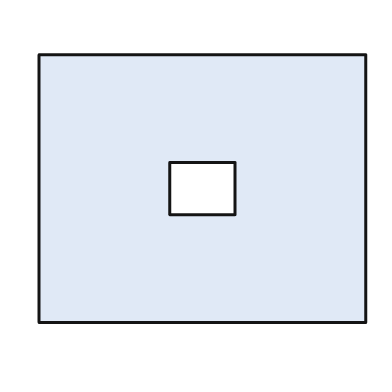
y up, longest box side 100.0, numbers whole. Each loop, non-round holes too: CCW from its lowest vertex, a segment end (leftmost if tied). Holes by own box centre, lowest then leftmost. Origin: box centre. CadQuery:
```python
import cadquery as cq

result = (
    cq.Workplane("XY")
    .moveTo(-50.0, -41.0)
    .lineTo(50.0, -41.0)
    .lineTo(50.0, 41.0)
    .lineTo(-50.0, 41.0)
    .close()
    .moveTo(-10.0, -8.0)
    .lineTo(10.0, -8.0)
    .lineTo(10.0, 8.0)
    .lineTo(-10.0, 8.0)
    .close()
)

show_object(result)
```